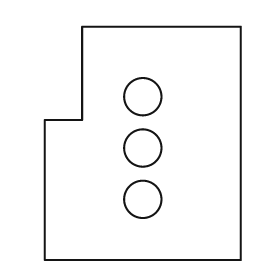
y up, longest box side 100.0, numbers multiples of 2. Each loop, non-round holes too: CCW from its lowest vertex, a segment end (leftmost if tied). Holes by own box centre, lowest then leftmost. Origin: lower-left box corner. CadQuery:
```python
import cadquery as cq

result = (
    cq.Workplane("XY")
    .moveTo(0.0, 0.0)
    .lineTo(84.0, 0.0)
    .lineTo(84.0, 100.0)
    .lineTo(16.0, 100.0)
    .lineTo(16.0, 60.0)
    .lineTo(0.0, 60.0)
    .close()
    .moveTo(42.0, 26.0)
    .circle(8.0)
    .moveTo(42.0, 48.0)
    .circle(8.0)
    .moveTo(42.0, 70.0)
    .circle(8.0)
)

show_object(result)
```